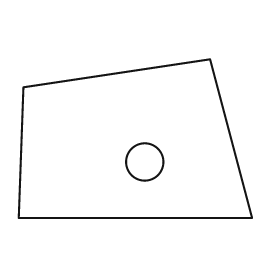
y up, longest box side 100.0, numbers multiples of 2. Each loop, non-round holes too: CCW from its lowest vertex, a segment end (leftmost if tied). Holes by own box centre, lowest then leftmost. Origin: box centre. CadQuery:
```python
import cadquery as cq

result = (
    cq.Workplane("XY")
    .moveTo(-50.0, -34.0)
    .lineTo(50.0, -34.0)
    .lineTo(32.0, 34.0)
    .lineTo(-48.0, 22.0)
    .close()
    .moveTo(4.0, -10.0)
    .circle(8.0)
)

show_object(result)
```